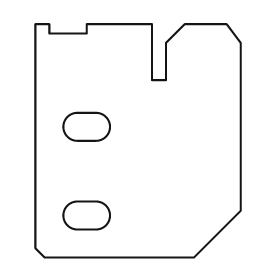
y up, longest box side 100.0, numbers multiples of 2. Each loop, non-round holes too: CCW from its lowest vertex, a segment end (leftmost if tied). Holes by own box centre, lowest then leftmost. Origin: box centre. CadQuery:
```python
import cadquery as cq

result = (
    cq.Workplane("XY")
    .moveTo(-40.0, -50.0)
    .lineTo(24.0, -50.0)
    .lineTo(44.0, -30.0)
    .lineTo(44.0, 42.0)
    .lineTo(38.0, 50.0)
    .lineTo(20.0, 50.0)
    .lineTo(12.0, 42.0)
    .lineTo(12.0, 26.0)
    .lineTo(6.0, 26.0)
    .lineTo(6.0, 50.0)
    .lineTo(-22.0, 50.0)
    .lineTo(-22.0, 46.0)
    .lineTo(-38.0, 46.0)
    .lineTo(-38.0, 50.0)
    .lineTo(-44.0, 50.0)
    .lineTo(-44.0, -46.0)
    .close()
    .moveTo(-26.0, -38.0)
    .lineTo(-18.0, -38.0)
    .threePointArc((-12.0, -32.0), (-18.0, -26.0))
    .lineTo(-26.0, -26.0)
    .threePointArc((-32.0, -32.0), (-26.0, -38.0))
    .close()
    .moveTo(-26.0, 0.0)
    .lineTo(-18.0, 0.0)
    .threePointArc((-12.0, 6.0), (-18.0, 12.0))
    .lineTo(-26.0, 12.0)
    .threePointArc((-32.0, 6.0), (-26.0, 0.0))
    .close()
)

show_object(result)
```